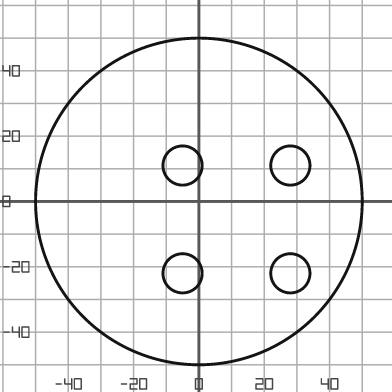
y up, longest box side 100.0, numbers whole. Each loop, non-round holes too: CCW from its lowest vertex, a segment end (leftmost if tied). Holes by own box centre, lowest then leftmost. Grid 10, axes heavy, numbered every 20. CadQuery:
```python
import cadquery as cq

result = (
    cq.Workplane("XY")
    .moveTo(0.0, 0.0)
    .circle(50.0)
    .moveTo(-5.0, -22.0)
    .circle(6.0)
    .moveTo(28.0, -22.0)
    .circle(6.0)
    .moveTo(-5.0, 11.0)
    .circle(6.0)
    .moveTo(28.0, 11.0)
    .circle(6.0)
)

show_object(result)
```